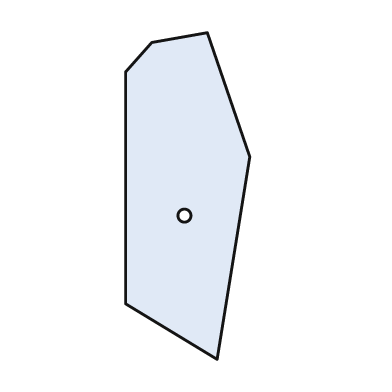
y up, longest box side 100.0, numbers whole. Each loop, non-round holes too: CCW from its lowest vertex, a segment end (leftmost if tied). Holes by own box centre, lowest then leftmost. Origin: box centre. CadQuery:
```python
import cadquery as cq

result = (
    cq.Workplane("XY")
    .moveTo(9.0, -50.0)
    .lineTo(19.0, 12.0)
    .lineTo(6.0, 50.0)
    .lineTo(-11.0, 47.0)
    .lineTo(-19.0, 38.0)
    .lineTo(-19.0, -33.0)
    .close()
    .moveTo(-1.0, -6.0)
    .circle(2.0)
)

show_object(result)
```